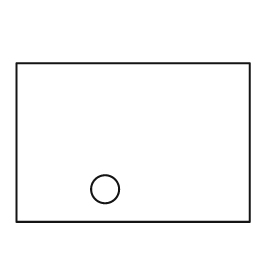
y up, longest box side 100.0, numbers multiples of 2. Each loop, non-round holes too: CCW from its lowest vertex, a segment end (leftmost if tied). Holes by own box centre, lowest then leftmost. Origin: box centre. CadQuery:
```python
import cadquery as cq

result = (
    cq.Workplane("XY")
    .moveTo(-50.0, -34.0)
    .lineTo(50.0, -34.0)
    .lineTo(50.0, 34.0)
    .lineTo(-50.0, 34.0)
    .close()
    .moveTo(-12.0, -20.0)
    .circle(6.0)
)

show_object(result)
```